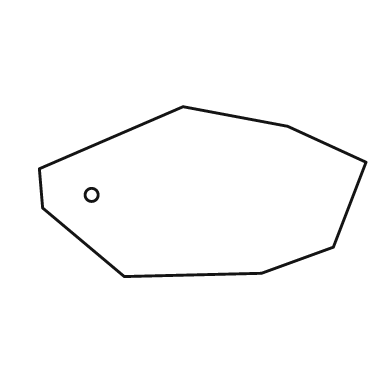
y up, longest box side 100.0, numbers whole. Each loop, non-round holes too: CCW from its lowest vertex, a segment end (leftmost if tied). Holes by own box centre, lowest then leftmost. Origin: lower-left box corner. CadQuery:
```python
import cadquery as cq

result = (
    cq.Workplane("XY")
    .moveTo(26.0, 0.0)
    .lineTo(68.0, 1.0)
    .lineTo(90.0, 9.0)
    .lineTo(100.0, 35.0)
    .lineTo(76.0, 46.0)
    .lineTo(44.0, 52.0)
    .lineTo(0.0, 33.0)
    .lineTo(1.0, 21.0)
    .close()
    .moveTo(16.0, 25.0)
    .circle(2.0)
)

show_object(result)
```